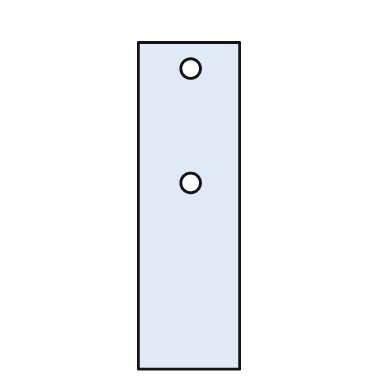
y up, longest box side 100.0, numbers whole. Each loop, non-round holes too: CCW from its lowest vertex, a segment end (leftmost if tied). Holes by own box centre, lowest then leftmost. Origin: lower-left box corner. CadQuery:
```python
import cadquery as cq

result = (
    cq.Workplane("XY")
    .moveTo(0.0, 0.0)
    .lineTo(31.0, 0.0)
    .lineTo(31.0, 100.0)
    .lineTo(0.0, 100.0)
    .close()
    .moveTo(16.0, 57.0)
    .circle(3.0)
    .moveTo(16.0, 92.0)
    .circle(3.0)
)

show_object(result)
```